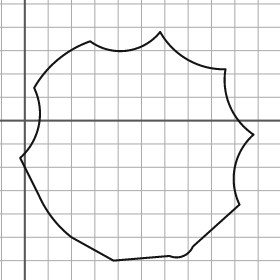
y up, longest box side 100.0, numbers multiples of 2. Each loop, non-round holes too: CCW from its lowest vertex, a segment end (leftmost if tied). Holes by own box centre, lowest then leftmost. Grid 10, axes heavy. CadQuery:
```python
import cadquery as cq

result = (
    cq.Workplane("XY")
    .moveTo(38.0, -60.0)
    .lineTo(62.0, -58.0)
    .threePointArc((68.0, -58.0), (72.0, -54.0))
    .lineTo(92.0, -36.0)
    .threePointArc((90.0, -20.0), (98.0, -6.0))
    .threePointArc((88.0, 6.0), (86.0, 22.0))
    .threePointArc((70.0, 26.0), (58.0, 38.0))
    .threePointArc((44.0, 30.0), (28.0, 34.0))
    .threePointArc((14.0, 26.0), (4.0, 14.0))
    .threePointArc((6.0, -2.0), (-2.0, -16.0))
    .lineTo(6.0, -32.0)
    .threePointArc((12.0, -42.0), (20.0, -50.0))
    .close()
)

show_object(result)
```